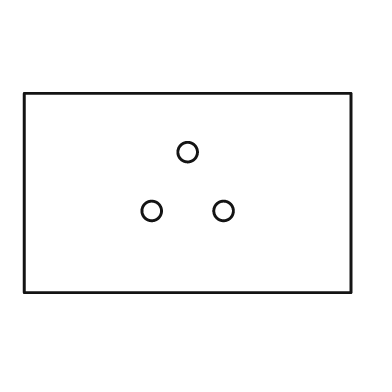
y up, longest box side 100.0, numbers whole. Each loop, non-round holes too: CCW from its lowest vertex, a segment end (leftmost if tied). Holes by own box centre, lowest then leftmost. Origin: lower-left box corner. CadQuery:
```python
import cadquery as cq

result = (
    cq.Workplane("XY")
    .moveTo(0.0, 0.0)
    .lineTo(100.0, 0.0)
    .lineTo(100.0, 61.0)
    .lineTo(0.0, 61.0)
    .close()
    .moveTo(39.0, 25.0)
    .circle(3.0)
    .moveTo(61.0, 25.0)
    .circle(3.0)
    .moveTo(50.0, 43.0)
    .circle(3.0)
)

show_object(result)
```